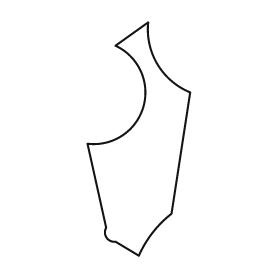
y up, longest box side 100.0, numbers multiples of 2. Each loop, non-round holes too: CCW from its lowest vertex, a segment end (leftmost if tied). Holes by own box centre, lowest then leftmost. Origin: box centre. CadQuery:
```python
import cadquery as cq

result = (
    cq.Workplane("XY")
    .moveTo(0.0, -50.0)
    .threePointArc((6.0, -40.0), (14.0, -32.0))
    .lineTo(22.0, 20.0)
    .threePointArc((8.0, 32.0), (4.0, 50.0))
    .lineTo(-10.0, 40.0)
    .threePointArc((2.0, 14.0), (-22.0, -2.0))
    .lineTo(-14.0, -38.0)
    .threePointArc((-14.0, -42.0), (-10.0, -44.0))
    .close()
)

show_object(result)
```